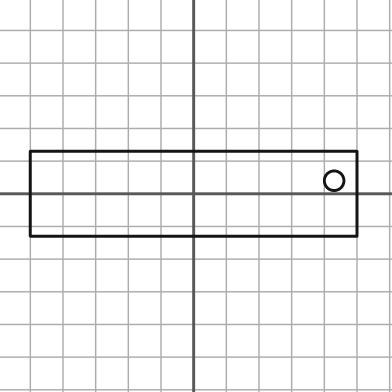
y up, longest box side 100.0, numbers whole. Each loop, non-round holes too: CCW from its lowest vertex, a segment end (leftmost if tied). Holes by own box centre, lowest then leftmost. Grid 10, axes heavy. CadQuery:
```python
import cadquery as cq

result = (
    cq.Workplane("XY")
    .moveTo(-50.0, -13.0)
    .lineTo(50.0, -13.0)
    .lineTo(50.0, 13.0)
    .lineTo(-50.0, 13.0)
    .close()
    .moveTo(43.0, 4.0)
    .circle(3.0)
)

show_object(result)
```